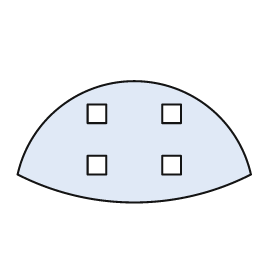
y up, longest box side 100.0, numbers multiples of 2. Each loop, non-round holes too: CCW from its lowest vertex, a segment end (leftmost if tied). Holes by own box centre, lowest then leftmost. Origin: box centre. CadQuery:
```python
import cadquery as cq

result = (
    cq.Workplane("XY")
    .moveTo(-50.0, -14.0)
    .threePointArc((0.0, -26.0), (50.0, -14.0))
    .threePointArc((0.0, 26.0), (-50.0, -14.0))
    .close()
    .moveTo(-20.0, -14.0)
    .lineTo(-12.0, -14.0)
    .lineTo(-12.0, -6.0)
    .lineTo(-20.0, -6.0)
    .close()
    .moveTo(12.0, -14.0)
    .lineTo(20.0, -14.0)
    .lineTo(20.0, -6.0)
    .lineTo(12.0, -6.0)
    .close()
    .moveTo(-20.0, 8.0)
    .lineTo(-12.0, 8.0)
    .lineTo(-12.0, 16.0)
    .lineTo(-20.0, 16.0)
    .close()
    .moveTo(12.0, 8.0)
    .lineTo(20.0, 8.0)
    .lineTo(20.0, 16.0)
    .lineTo(12.0, 16.0)
    .close()
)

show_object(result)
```